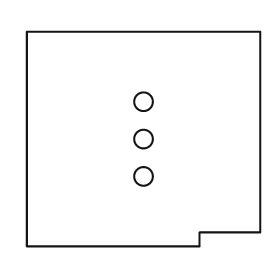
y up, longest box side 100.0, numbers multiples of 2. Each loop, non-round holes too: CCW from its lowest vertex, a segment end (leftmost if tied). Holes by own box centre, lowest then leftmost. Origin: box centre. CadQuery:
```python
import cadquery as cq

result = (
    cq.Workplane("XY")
    .moveTo(-50.0, -46.0)
    .lineTo(24.0, -46.0)
    .lineTo(24.0, -40.0)
    .lineTo(50.0, -40.0)
    .lineTo(50.0, 46.0)
    .lineTo(-50.0, 46.0)
    .close()
    .moveTo(0.0, -16.0)
    .circle(4.0)
    .moveTo(0.0, 0.0)
    .circle(4.0)
    .moveTo(0.0, 16.0)
    .circle(4.0)
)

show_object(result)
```